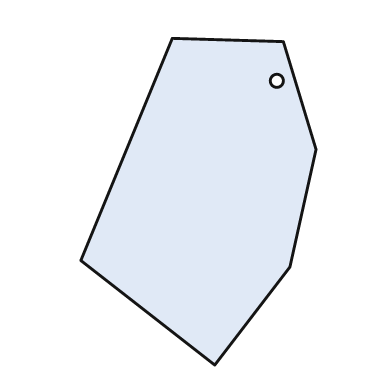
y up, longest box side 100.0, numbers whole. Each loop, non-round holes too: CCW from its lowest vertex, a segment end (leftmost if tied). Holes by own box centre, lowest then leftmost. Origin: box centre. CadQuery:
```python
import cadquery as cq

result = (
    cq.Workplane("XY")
    .moveTo(5.0, -50.0)
    .lineTo(28.0, -20.0)
    .lineTo(36.0, 16.0)
    .lineTo(26.0, 49.0)
    .lineTo(-8.0, 50.0)
    .lineTo(-36.0, -18.0)
    .close()
    .moveTo(24.0, 37.0)
    .circle(2.0)
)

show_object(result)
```